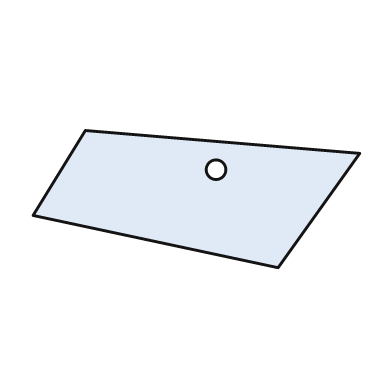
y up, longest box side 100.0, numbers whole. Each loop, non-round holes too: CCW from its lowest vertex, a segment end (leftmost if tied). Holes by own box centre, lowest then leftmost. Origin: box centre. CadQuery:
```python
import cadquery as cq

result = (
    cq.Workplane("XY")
    .moveTo(25.0, -21.0)
    .lineTo(50.0, 14.0)
    .lineTo(-34.0, 21.0)
    .lineTo(-50.0, -5.0)
    .close()
    .moveTo(6.0, 9.0)
    .circle(3.0)
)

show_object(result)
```